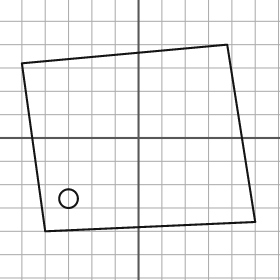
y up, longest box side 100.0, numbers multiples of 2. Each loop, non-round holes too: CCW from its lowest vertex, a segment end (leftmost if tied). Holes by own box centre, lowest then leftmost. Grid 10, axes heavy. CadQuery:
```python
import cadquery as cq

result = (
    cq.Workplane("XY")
    .moveTo(-40.0, -40.0)
    .lineTo(50.0, -36.0)
    .lineTo(38.0, 40.0)
    .lineTo(-50.0, 32.0)
    .close()
    .moveTo(-30.0, -26.0)
    .circle(4.0)
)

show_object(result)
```